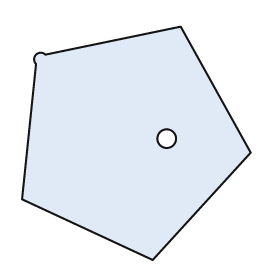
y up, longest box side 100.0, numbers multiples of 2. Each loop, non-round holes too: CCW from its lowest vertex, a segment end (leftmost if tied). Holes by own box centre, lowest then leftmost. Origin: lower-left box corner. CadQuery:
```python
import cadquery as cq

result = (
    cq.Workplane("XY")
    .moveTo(56.0, 0.0)
    .lineTo(98.0, 46.0)
    .lineTo(68.0, 100.0)
    .lineTo(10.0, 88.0)
    .threePointArc((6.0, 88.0), (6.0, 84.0))
    .lineTo(0.0, 26.0)
    .close()
    .moveTo(62.0, 52.0)
    .circle(4.0)
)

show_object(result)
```